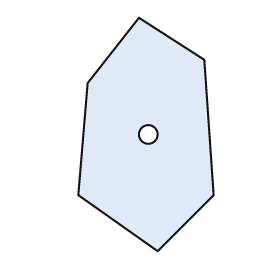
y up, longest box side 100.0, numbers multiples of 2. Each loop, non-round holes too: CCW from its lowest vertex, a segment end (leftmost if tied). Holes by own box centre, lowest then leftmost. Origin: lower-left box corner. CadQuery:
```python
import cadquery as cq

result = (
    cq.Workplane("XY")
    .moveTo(34.0, 0.0)
    .lineTo(58.0, 24.0)
    .lineTo(54.0, 82.0)
    .lineTo(26.0, 100.0)
    .lineTo(4.0, 72.0)
    .lineTo(0.0, 24.0)
    .close()
    .moveTo(30.0, 50.0)
    .circle(4.0)
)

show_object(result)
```